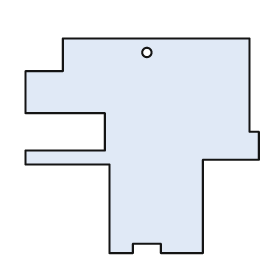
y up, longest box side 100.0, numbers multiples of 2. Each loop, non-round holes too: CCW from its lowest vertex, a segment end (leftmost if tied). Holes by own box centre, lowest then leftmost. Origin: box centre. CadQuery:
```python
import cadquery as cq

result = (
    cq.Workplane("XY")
    .moveTo(-14.0, -46.0)
    .lineTo(-4.0, -46.0)
    .lineTo(-4.0, -42.0)
    .lineTo(8.0, -42.0)
    .lineTo(8.0, -46.0)
    .lineTo(26.0, -46.0)
    .lineTo(26.0, -6.0)
    .lineTo(50.0, -6.0)
    .lineTo(50.0, 6.0)
    .lineTo(46.0, 6.0)
    .lineTo(46.0, 46.0)
    .lineTo(-34.0, 46.0)
    .lineTo(-34.0, 32.0)
    .lineTo(-50.0, 32.0)
    .lineTo(-50.0, 14.0)
    .lineTo(-16.0, 14.0)
    .lineTo(-16.0, -2.0)
    .lineTo(-50.0, -2.0)
    .lineTo(-50.0, -8.0)
    .lineTo(-14.0, -8.0)
    .close()
    .moveTo(2.0, 40.0)
    .circle(2.0)
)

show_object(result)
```